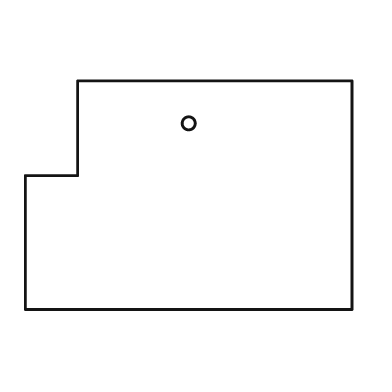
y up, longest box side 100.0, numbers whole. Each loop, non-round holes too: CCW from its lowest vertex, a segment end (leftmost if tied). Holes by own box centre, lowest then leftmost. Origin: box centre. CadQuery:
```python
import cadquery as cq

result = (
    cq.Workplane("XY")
    .moveTo(-50.0, -35.0)
    .lineTo(50.0, -35.0)
    .lineTo(50.0, 35.0)
    .lineTo(-34.0, 35.0)
    .lineTo(-34.0, 6.0)
    .lineTo(-50.0, 6.0)
    .close()
    .moveTo(0.0, 22.0)
    .circle(2.0)
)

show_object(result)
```